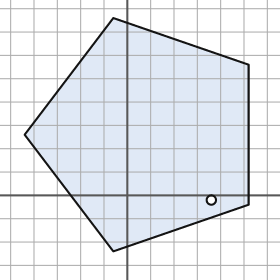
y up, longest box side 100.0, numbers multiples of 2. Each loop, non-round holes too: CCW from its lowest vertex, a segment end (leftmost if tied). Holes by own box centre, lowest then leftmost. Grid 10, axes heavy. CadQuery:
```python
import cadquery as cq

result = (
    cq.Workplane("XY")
    .moveTo(-6.0, -24.0)
    .lineTo(52.0, -4.0)
    .lineTo(52.0, 56.0)
    .lineTo(-6.0, 76.0)
    .lineTo(-44.0, 26.0)
    .close()
    .moveTo(36.0, -2.0)
    .circle(2.0)
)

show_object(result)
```